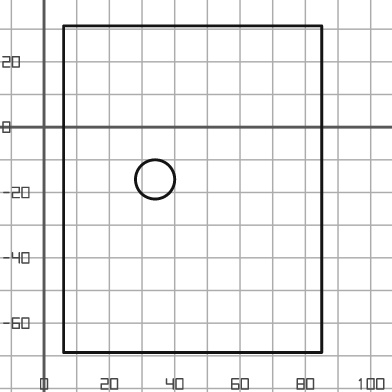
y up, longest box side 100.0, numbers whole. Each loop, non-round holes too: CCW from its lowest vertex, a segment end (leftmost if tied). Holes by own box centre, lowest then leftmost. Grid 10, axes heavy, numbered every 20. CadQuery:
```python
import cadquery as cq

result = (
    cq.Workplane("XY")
    .moveTo(6.0, -69.0)
    .lineTo(85.0, -69.0)
    .lineTo(85.0, 31.0)
    .lineTo(6.0, 31.0)
    .close()
    .moveTo(34.0, -16.0)
    .circle(6.0)
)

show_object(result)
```